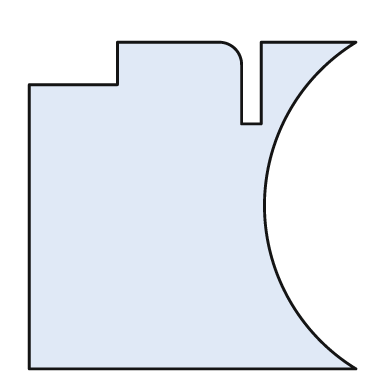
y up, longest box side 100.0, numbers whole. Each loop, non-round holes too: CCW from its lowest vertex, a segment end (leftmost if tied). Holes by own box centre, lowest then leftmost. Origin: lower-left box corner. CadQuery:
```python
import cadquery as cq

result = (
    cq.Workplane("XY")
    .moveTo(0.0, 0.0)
    .lineTo(100.0, 0.0)
    .threePointArc((72.0, 50.0), (100.0, 100.0))
    .lineTo(71.0, 100.0)
    .lineTo(71.0, 75.0)
    .lineTo(65.0, 75.0)
    .lineTo(65.0, 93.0)
    .threePointArc((63.0, 98.0), (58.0, 100.0))
    .lineTo(27.0, 100.0)
    .lineTo(27.0, 87.0)
    .lineTo(0.0, 87.0)
    .close()
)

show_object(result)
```